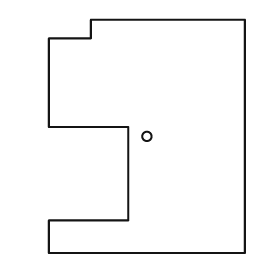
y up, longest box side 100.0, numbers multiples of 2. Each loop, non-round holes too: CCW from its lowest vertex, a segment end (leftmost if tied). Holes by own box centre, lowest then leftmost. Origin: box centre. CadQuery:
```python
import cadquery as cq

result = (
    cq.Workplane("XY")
    .moveTo(-42.0, -50.0)
    .lineTo(42.0, -50.0)
    .lineTo(42.0, 50.0)
    .lineTo(-24.0, 50.0)
    .lineTo(-24.0, 42.0)
    .lineTo(-42.0, 42.0)
    .lineTo(-42.0, 4.0)
    .lineTo(-8.0, 4.0)
    .lineTo(-8.0, -36.0)
    .lineTo(-42.0, -36.0)
    .close()
    .moveTo(0.0, 0.0)
    .circle(2.0)
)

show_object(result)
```